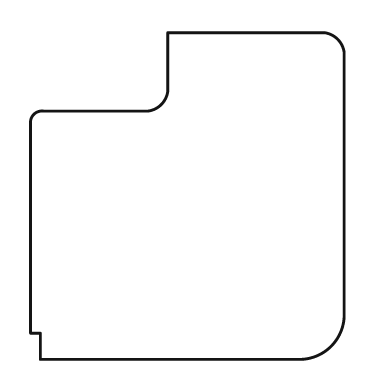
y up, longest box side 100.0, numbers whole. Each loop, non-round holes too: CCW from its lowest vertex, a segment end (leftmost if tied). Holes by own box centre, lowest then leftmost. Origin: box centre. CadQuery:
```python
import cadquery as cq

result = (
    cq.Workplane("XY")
    .moveTo(-45.0, -50.0)
    .lineTo(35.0, -50.0)
    .threePointArc((44.0, -46.0), (48.0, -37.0))
    .lineTo(48.0, 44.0)
    .threePointArc((46.0, 48.0), (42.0, 50.0))
    .lineTo(-6.0, 50.0)
    .lineTo(-6.0, 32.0)
    .threePointArc((-8.0, 28.0), (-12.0, 26.0))
    .lineTo(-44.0, 26.0)
    .threePointArc((-47.0, 25.0), (-48.0, 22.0))
    .lineTo(-48.0, -42.0)
    .lineTo(-45.0, -42.0)
    .close()
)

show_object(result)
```